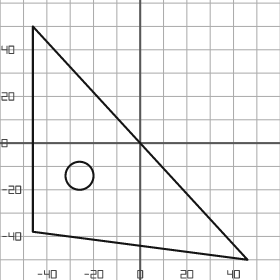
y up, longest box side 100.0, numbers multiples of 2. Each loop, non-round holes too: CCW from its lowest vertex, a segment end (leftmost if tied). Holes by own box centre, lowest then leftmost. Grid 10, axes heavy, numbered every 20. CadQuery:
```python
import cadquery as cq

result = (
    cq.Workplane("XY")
    .moveTo(46.0, -50.0)
    .lineTo(-46.0, 50.0)
    .lineTo(-46.0, -38.0)
    .close()
    .moveTo(-26.0, -14.0)
    .circle(6.0)
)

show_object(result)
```